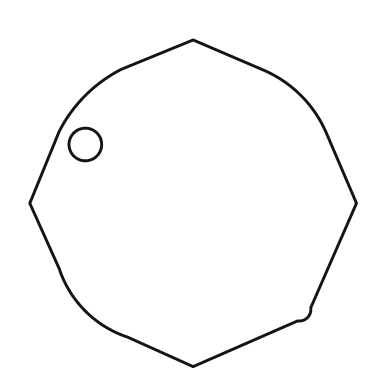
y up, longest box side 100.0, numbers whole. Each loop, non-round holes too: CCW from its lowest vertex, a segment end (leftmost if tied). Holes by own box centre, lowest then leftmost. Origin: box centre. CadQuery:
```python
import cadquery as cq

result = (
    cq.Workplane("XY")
    .moveTo(0.0, -50.0)
    .lineTo(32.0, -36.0)
    .threePointArc((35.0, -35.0), (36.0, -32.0))
    .lineTo(50.0, 0.0)
    .lineTo(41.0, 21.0)
    .threePointArc((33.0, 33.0), (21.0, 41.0))
    .lineTo(0.0, 50.0)
    .lineTo(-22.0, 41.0)
    .threePointArc((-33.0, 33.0), (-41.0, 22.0))
    .lineTo(-50.0, 0.0)
    .lineTo(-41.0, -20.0)
    .threePointArc((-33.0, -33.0), (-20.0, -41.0))
    .close()
    .moveTo(-33.0, 18.0)
    .circle(5.0)
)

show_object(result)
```